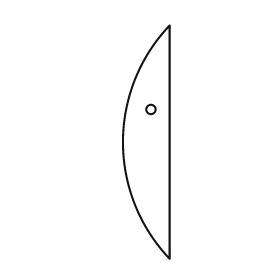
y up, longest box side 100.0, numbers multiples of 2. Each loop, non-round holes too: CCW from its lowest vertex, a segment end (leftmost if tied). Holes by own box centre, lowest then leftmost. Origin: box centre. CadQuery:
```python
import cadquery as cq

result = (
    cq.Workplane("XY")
    .moveTo(10.0, -50.0)
    .lineTo(10.0, 50.0)
    .threePointArc((-10.0, 0.0), (10.0, -50.0))
    .close()
    .moveTo(2.0, 14.0)
    .circle(2.0)
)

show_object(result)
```